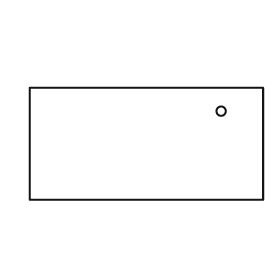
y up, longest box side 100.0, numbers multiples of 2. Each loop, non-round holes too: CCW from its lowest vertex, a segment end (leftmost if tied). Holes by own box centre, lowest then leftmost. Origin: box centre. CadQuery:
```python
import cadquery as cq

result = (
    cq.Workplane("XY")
    .moveTo(-50.0, -24.0)
    .lineTo(50.0, -24.0)
    .lineTo(50.0, 24.0)
    .lineTo(-50.0, 24.0)
    .close()
    .moveTo(32.0, 14.0)
    .circle(2.0)
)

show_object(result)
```